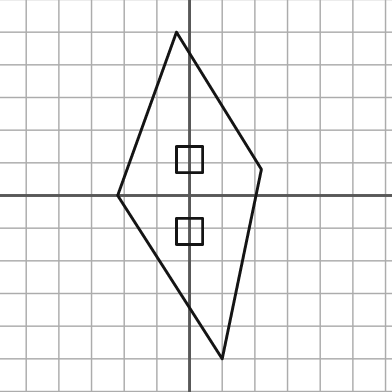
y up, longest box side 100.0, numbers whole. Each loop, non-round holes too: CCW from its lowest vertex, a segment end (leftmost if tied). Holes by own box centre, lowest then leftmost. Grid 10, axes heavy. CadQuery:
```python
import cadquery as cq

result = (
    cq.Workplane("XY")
    .moveTo(10.0, -50.0)
    .lineTo(22.0, 8.0)
    .lineTo(-4.0, 50.0)
    .lineTo(-22.0, 0.0)
    .close()
    .moveTo(-4.0, -15.0)
    .lineTo(4.0, -15.0)
    .lineTo(4.0, -7.0)
    .lineTo(-4.0, -7.0)
    .close()
    .moveTo(-4.0, 7.0)
    .lineTo(4.0, 7.0)
    .lineTo(4.0, 15.0)
    .lineTo(-4.0, 15.0)
    .close()
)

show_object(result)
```